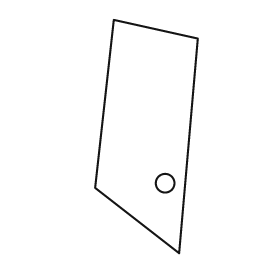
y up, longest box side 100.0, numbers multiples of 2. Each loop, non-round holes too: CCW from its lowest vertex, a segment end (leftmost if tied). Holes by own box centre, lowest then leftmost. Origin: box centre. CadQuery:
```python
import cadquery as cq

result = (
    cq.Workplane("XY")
    .moveTo(14.0, -50.0)
    .lineTo(22.0, 42.0)
    .lineTo(-14.0, 50.0)
    .lineTo(-22.0, -22.0)
    .close()
    .moveTo(8.0, -20.0)
    .circle(4.0)
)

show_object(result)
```